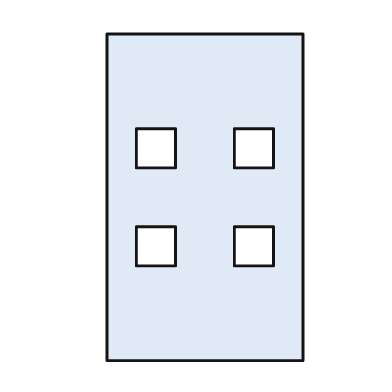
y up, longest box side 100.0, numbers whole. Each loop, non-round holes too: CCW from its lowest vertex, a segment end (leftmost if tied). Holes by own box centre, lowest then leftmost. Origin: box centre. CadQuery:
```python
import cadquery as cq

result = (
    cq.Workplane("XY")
    .moveTo(-30.0, -50.0)
    .lineTo(30.0, -50.0)
    .lineTo(30.0, 50.0)
    .lineTo(-30.0, 50.0)
    .close()
    .moveTo(-21.0, -21.0)
    .lineTo(-9.0, -21.0)
    .lineTo(-9.0, -9.0)
    .lineTo(-21.0, -9.0)
    .close()
    .moveTo(9.0, -21.0)
    .lineTo(21.0, -21.0)
    .lineTo(21.0, -9.0)
    .lineTo(9.0, -9.0)
    .close()
    .moveTo(-21.0, 9.0)
    .lineTo(-9.0, 9.0)
    .lineTo(-9.0, 21.0)
    .lineTo(-21.0, 21.0)
    .close()
    .moveTo(9.0, 9.0)
    .lineTo(21.0, 9.0)
    .lineTo(21.0, 21.0)
    .lineTo(9.0, 21.0)
    .close()
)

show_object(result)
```